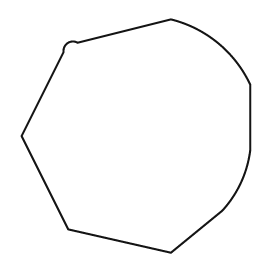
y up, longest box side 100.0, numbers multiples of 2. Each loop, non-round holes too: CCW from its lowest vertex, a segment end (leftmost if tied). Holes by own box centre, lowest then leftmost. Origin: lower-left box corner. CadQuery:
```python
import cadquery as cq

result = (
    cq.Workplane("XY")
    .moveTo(64.0, 0.0)
    .lineTo(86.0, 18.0)
    .threePointArc((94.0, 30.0), (98.0, 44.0))
    .lineTo(98.0, 72.0)
    .threePointArc((84.0, 90.0), (64.0, 100.0))
    .lineTo(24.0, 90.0)
    .threePointArc((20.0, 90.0), (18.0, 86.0))
    .lineTo(0.0, 50.0)
    .lineTo(20.0, 10.0)
    .close()
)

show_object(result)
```